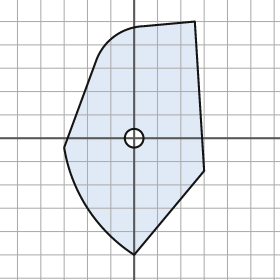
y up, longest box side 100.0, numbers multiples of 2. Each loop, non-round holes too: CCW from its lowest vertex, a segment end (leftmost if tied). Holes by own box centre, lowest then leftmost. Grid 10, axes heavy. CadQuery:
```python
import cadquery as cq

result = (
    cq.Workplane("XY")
    .moveTo(0.0, -50.0)
    .lineTo(30.0, -14.0)
    .lineTo(26.0, 50.0)
    .lineTo(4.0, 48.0)
    .threePointArc((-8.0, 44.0), (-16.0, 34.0))
    .lineTo(-30.0, -4.0)
    .threePointArc((-20.0, -30.0), (0.0, -50.0))
    .close()
    .moveTo(0.0, 0.0)
    .circle(4.0)
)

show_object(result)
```